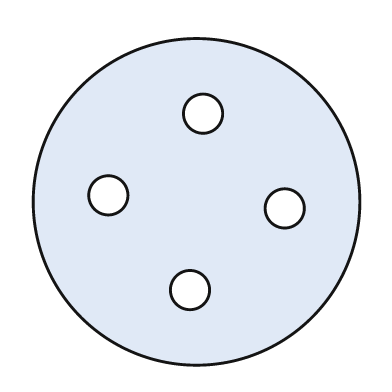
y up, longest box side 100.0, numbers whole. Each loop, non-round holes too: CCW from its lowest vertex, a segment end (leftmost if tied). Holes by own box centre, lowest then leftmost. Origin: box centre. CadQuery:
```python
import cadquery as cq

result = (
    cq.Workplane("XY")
    .moveTo(0.0, 0.0)
    .circle(50.0)
    .moveTo(-2.0, -27.0)
    .circle(6.0)
    .moveTo(27.0, -2.0)
    .circle(6.0)
    .moveTo(-27.0, 2.0)
    .circle(6.0)
    .moveTo(2.0, 27.0)
    .circle(6.0)
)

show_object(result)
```